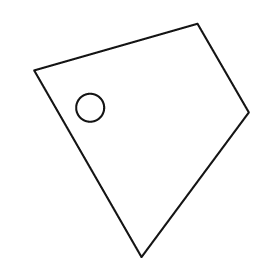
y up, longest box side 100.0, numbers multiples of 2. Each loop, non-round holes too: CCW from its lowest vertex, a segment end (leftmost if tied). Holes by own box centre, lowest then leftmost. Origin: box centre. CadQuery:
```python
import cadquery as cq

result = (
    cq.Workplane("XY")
    .moveTo(0.0, -50.0)
    .lineTo(46.0, 12.0)
    .lineTo(24.0, 50.0)
    .lineTo(-46.0, 30.0)
    .close()
    .moveTo(-22.0, 14.0)
    .circle(6.0)
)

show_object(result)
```